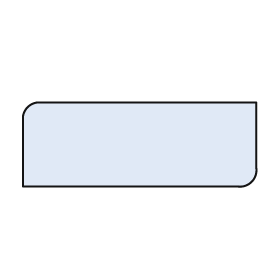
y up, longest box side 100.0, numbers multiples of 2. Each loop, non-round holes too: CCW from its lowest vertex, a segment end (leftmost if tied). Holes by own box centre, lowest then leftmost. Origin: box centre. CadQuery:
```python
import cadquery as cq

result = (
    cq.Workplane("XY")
    .moveTo(-50.0, -18.0)
    .lineTo(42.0, -18.0)
    .threePointArc((48.0, -16.0), (50.0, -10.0))
    .lineTo(50.0, 18.0)
    .lineTo(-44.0, 18.0)
    .threePointArc((-48.0, 16.0), (-50.0, 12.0))
    .close()
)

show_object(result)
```